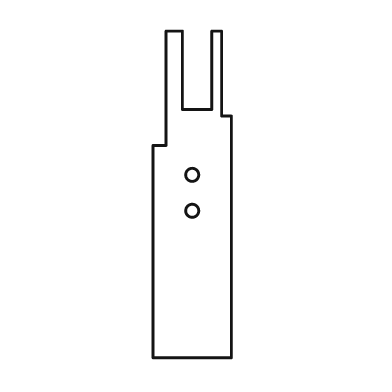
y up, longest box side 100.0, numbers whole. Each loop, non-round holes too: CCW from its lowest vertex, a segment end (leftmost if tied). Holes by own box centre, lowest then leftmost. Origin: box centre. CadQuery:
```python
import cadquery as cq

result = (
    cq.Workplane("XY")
    .moveTo(-12.0, -50.0)
    .lineTo(12.0, -50.0)
    .lineTo(12.0, 24.0)
    .lineTo(9.0, 24.0)
    .lineTo(9.0, 50.0)
    .lineTo(6.0, 50.0)
    .lineTo(6.0, 26.0)
    .lineTo(-3.0, 26.0)
    .lineTo(-3.0, 50.0)
    .lineTo(-8.0, 50.0)
    .lineTo(-8.0, 15.0)
    .lineTo(-12.0, 15.0)
    .close()
    .moveTo(0.0, -5.0)
    .circle(2.0)
    .moveTo(0.0, 6.0)
    .circle(2.0)
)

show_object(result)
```